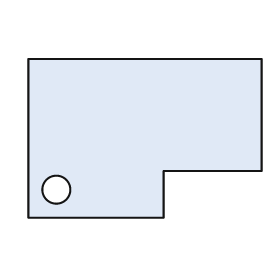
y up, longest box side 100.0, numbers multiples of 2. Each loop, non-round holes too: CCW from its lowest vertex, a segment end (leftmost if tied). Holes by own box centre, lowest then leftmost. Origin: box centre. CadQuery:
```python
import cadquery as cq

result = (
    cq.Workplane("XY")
    .moveTo(-50.0, -34.0)
    .lineTo(8.0, -34.0)
    .lineTo(8.0, -14.0)
    .lineTo(50.0, -14.0)
    .lineTo(50.0, 34.0)
    .lineTo(-50.0, 34.0)
    .close()
    .moveTo(-38.0, -22.0)
    .circle(6.0)
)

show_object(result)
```